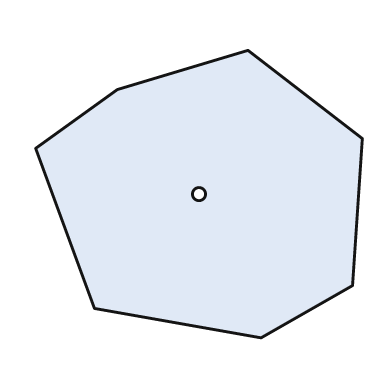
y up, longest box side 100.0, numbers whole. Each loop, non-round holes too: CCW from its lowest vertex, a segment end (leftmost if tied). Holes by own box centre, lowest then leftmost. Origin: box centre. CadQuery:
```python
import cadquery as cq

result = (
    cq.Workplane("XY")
    .moveTo(19.0, -44.0)
    .lineTo(47.0, -28.0)
    .lineTo(50.0, 17.0)
    .lineTo(15.0, 44.0)
    .lineTo(-25.0, 32.0)
    .lineTo(-50.0, 14.0)
    .lineTo(-32.0, -35.0)
    .close()
    .moveTo(0.0, 0.0)
    .circle(2.0)
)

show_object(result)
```